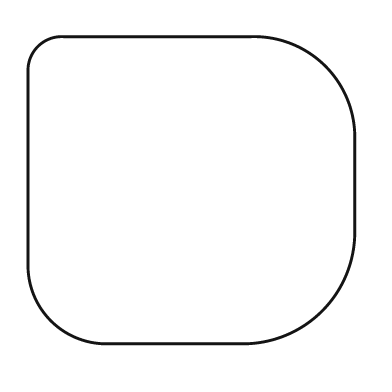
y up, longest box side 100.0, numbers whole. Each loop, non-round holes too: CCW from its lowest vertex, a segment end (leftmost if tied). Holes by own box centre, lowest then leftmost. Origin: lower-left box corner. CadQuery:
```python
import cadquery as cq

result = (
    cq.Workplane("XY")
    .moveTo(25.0, 0.0)
    .lineTo(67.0, 0.0)
    .threePointArc((90.0, 10.0), (100.0, 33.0))
    .lineTo(100.0, 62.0)
    .threePointArc((91.0, 85.0), (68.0, 94.0))
    .lineTo(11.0, 94.0)
    .threePointArc((3.0, 91.0), (0.0, 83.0))
    .lineTo(0.0, 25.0)
    .threePointArc((7.0, 7.0), (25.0, 0.0))
    .close()
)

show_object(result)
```